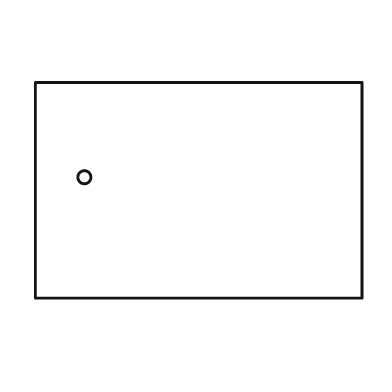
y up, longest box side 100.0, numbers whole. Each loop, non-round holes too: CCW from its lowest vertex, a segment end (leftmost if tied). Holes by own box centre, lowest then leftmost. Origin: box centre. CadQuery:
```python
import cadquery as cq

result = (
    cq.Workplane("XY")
    .moveTo(-50.0, -33.0)
    .lineTo(50.0, -33.0)
    .lineTo(50.0, 33.0)
    .lineTo(-50.0, 33.0)
    .close()
    .moveTo(-35.0, 4.0)
    .circle(2.0)
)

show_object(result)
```